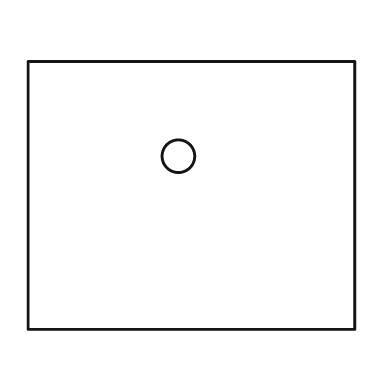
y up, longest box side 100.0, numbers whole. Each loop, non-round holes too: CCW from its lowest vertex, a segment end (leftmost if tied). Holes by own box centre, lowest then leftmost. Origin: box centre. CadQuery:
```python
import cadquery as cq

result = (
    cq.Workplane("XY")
    .moveTo(-50.0, -41.0)
    .lineTo(50.0, -41.0)
    .lineTo(50.0, 41.0)
    .lineTo(-50.0, 41.0)
    .close()
    .moveTo(-4.0, 12.0)
    .circle(5.0)
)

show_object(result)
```